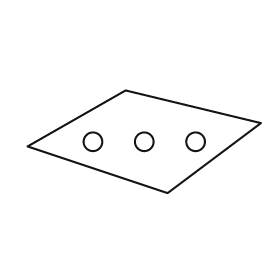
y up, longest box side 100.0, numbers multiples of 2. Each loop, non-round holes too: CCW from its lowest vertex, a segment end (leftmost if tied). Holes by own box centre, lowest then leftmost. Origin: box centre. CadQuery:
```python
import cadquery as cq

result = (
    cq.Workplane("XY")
    .moveTo(10.0, -22.0)
    .lineTo(50.0, 8.0)
    .lineTo(-8.0, 22.0)
    .lineTo(-50.0, -2.0)
    .close()
    .moveTo(-22.0, 0.0)
    .circle(4.0)
    .moveTo(0.0, 0.0)
    .circle(4.0)
    .moveTo(22.0, 0.0)
    .circle(4.0)
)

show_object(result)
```